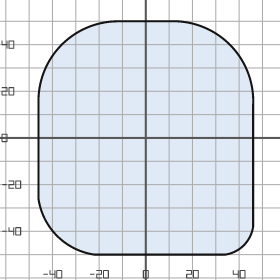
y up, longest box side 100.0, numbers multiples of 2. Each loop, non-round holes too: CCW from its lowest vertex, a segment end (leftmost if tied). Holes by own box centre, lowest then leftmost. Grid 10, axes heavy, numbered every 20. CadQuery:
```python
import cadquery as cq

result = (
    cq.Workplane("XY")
    .moveTo(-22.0, -50.0)
    .lineTo(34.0, -50.0)
    .threePointArc((42.0, -46.0), (46.0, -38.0))
    .lineTo(46.0, 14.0)
    .threePointArc((36.0, 40.0), (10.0, 50.0))
    .lineTo(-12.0, 50.0)
    .threePointArc((-36.0, 40.0), (-46.0, 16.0))
    .lineTo(-46.0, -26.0)
    .threePointArc((-38.0, -42.0), (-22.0, -50.0))
    .close()
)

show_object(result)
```